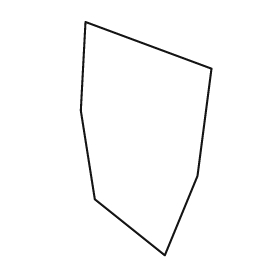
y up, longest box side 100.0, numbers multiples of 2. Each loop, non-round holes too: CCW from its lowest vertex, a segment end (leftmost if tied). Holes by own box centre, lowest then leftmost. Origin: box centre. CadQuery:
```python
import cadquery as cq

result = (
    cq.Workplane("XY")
    .moveTo(8.0, -50.0)
    .lineTo(22.0, -16.0)
    .lineTo(28.0, 30.0)
    .lineTo(-26.0, 50.0)
    .lineTo(-28.0, 12.0)
    .lineTo(-22.0, -26.0)
    .close()
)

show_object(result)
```